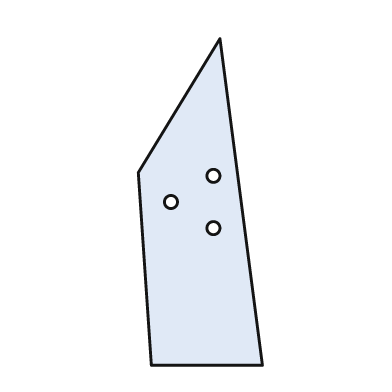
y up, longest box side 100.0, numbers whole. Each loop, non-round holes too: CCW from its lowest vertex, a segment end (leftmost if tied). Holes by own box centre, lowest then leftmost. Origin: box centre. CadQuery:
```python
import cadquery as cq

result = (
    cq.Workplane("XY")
    .moveTo(-15.0, -50.0)
    .lineTo(19.0, -50.0)
    .lineTo(6.0, 50.0)
    .lineTo(-19.0, 9.0)
    .close()
    .moveTo(4.0, -8.0)
    .circle(2.0)
    .moveTo(-9.0, 0.0)
    .circle(2.0)
    .moveTo(4.0, 8.0)
    .circle(2.0)
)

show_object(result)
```